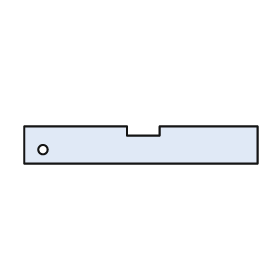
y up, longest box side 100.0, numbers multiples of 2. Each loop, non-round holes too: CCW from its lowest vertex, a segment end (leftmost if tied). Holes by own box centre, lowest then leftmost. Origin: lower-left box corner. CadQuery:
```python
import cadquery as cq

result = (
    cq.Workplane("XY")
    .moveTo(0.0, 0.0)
    .lineTo(100.0, 0.0)
    .lineTo(100.0, 16.0)
    .lineTo(58.0, 16.0)
    .lineTo(58.0, 12.0)
    .lineTo(44.0, 12.0)
    .lineTo(44.0, 16.0)
    .lineTo(0.0, 16.0)
    .close()
    .moveTo(8.0, 6.0)
    .circle(2.0)
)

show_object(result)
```